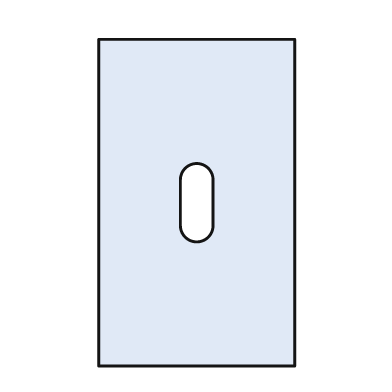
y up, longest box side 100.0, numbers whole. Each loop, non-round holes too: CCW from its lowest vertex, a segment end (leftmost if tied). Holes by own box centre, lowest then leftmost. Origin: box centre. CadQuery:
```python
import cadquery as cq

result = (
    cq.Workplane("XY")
    .moveTo(-30.0, -50.0)
    .lineTo(30.0, -50.0)
    .lineTo(30.0, 50.0)
    .lineTo(-30.0, 50.0)
    .close()
    .moveTo(-5.0, -7.0)
    .threePointArc((0.0, -12.0), (5.0, -7.0))
    .lineTo(5.0, 7.0)
    .threePointArc((0.0, 12.0), (-5.0, 7.0))
    .close()
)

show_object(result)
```